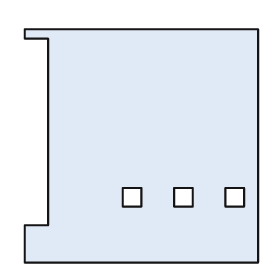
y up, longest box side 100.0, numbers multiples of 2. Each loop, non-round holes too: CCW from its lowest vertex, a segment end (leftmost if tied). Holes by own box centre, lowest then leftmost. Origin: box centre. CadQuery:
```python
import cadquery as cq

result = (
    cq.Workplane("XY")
    .moveTo(-50.0, -50.0)
    .lineTo(50.0, -50.0)
    .lineTo(50.0, 50.0)
    .lineTo(-50.0, 50.0)
    .lineTo(-50.0, 46.0)
    .lineTo(-40.0, 46.0)
    .lineTo(-40.0, -34.0)
    .lineTo(-50.0, -34.0)
    .close()
    .moveTo(-8.0, -26.0)
    .lineTo(0.0, -26.0)
    .lineTo(0.0, -18.0)
    .lineTo(-8.0, -18.0)
    .close()
    .moveTo(14.0, -26.0)
    .lineTo(22.0, -26.0)
    .lineTo(22.0, -18.0)
    .lineTo(14.0, -18.0)
    .close()
    .moveTo(36.0, -26.0)
    .lineTo(44.0, -26.0)
    .lineTo(44.0, -18.0)
    .lineTo(36.0, -18.0)
    .close()
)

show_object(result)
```